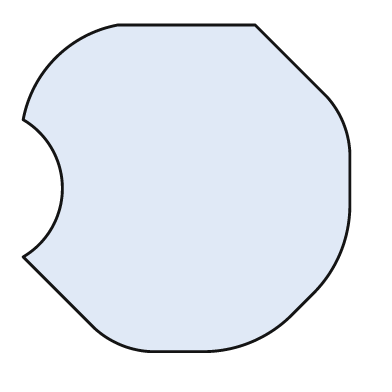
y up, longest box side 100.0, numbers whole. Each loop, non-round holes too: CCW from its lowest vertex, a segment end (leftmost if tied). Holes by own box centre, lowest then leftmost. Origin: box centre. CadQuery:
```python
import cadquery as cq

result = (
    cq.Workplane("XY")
    .moveTo(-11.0, -50.0)
    .lineTo(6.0, -50.0)
    .threePointArc((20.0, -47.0), (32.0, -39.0))
    .lineTo(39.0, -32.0)
    .threePointArc((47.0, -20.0), (50.0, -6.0))
    .lineTo(50.0, 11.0)
    .threePointArc((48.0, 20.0), (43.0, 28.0))
    .lineTo(21.0, 50.0)
    .lineTo(-21.0, 50.0)
    .threePointArc((-40.0, 40.0), (-50.0, 21.0))
    .threePointArc((-38.0, 0.0), (-50.0, -21.0))
    .lineTo(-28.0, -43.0)
    .threePointArc((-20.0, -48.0), (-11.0, -50.0))
    .close()
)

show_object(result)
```